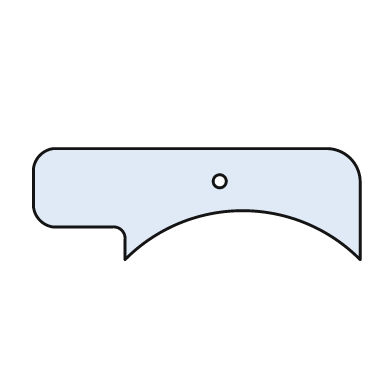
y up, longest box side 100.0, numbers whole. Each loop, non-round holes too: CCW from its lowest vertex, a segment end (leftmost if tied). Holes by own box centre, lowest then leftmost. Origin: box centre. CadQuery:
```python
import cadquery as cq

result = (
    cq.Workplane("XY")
    .moveTo(-22.0, -17.0)
    .threePointArc((14.0, -2.0), (50.0, -17.0))
    .lineTo(50.0, 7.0)
    .threePointArc((47.0, 14.0), (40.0, 17.0))
    .lineTo(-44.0, 17.0)
    .threePointArc((-48.0, 15.0), (-50.0, 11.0))
    .lineTo(-50.0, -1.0)
    .threePointArc((-48.0, -5.0), (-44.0, -7.0))
    .lineTo(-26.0, -7.0)
    .threePointArc((-23.0, -8.0), (-22.0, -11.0))
    .close()
    .moveTo(7.0, 7.0)
    .circle(2.0)
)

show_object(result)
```